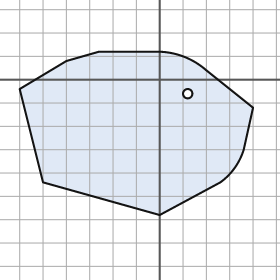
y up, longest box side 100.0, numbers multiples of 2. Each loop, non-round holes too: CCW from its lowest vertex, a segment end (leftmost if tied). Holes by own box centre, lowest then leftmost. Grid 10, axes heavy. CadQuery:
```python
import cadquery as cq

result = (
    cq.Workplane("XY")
    .moveTo(0.0, -58.0)
    .lineTo(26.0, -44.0)
    .threePointArc((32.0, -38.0), (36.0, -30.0))
    .lineTo(40.0, -12.0)
    .lineTo(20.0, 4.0)
    .threePointArc((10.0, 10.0), (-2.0, 12.0))
    .lineTo(-26.0, 12.0)
    .lineTo(-40.0, 8.0)
    .lineTo(-60.0, -4.0)
    .lineTo(-50.0, -44.0)
    .close()
    .moveTo(12.0, -6.0)
    .circle(2.0)
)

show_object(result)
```